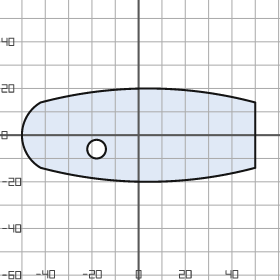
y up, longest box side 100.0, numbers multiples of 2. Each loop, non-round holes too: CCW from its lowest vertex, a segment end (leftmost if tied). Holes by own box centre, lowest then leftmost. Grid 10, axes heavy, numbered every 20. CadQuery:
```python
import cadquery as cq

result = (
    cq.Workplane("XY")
    .moveTo(-42.0, -14.0)
    .threePointArc((4.0, -20.0), (50.0, -14.0))
    .lineTo(50.0, 14.0)
    .threePointArc((4.0, 20.0), (-42.0, 14.0))
    .threePointArc((-50.0, 0.0), (-42.0, -14.0))
    .close()
    .moveTo(-18.0, -6.0)
    .circle(4.0)
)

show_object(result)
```